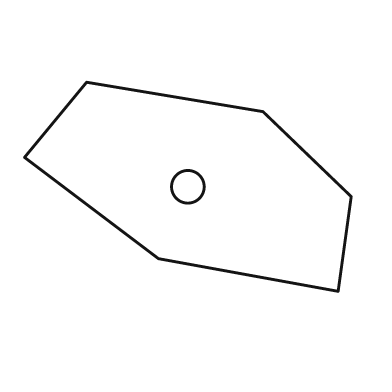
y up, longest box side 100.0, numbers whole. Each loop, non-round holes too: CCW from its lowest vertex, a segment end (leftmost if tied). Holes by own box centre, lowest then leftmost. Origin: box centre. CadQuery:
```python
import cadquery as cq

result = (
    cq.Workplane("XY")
    .moveTo(46.0, -32.0)
    .lineTo(50.0, -3.0)
    .lineTo(23.0, 23.0)
    .lineTo(-31.0, 32.0)
    .lineTo(-50.0, 9.0)
    .lineTo(-9.0, -22.0)
    .close()
    .moveTo(0.0, 0.0)
    .circle(5.0)
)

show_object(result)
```